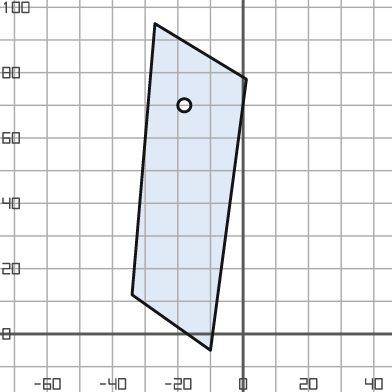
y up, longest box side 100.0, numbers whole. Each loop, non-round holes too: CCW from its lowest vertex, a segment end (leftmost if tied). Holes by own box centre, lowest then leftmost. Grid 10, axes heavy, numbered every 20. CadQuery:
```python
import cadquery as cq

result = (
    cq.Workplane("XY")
    .moveTo(-10.0, -5.0)
    .lineTo(1.0, 78.0)
    .lineTo(-27.0, 95.0)
    .lineTo(-34.0, 12.0)
    .close()
    .moveTo(-18.0, 70.0)
    .circle(2.0)
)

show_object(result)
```